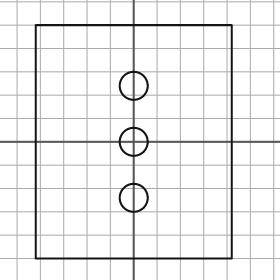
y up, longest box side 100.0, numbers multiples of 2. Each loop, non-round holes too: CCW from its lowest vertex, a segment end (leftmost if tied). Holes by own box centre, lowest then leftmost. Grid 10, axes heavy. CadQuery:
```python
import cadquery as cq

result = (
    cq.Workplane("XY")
    .moveTo(-42.0, -50.0)
    .lineTo(42.0, -50.0)
    .lineTo(42.0, 50.0)
    .lineTo(-42.0, 50.0)
    .close()
    .moveTo(0.0, -24.0)
    .circle(6.0)
    .moveTo(0.0, 0.0)
    .circle(6.0)
    .moveTo(0.0, 24.0)
    .circle(6.0)
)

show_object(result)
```